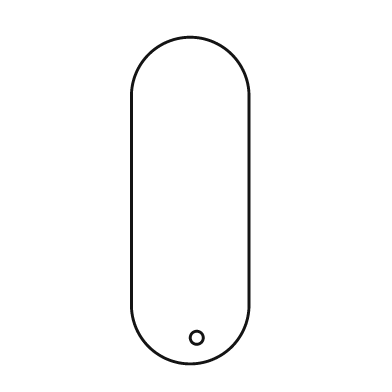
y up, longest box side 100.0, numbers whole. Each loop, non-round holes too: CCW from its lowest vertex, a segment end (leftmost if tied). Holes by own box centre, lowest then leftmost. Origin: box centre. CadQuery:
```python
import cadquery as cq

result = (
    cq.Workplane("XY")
    .moveTo(-18.0, -32.0)
    .threePointArc((0.0, -50.0), (18.0, -32.0))
    .lineTo(18.0, 32.0)
    .threePointArc((0.0, 50.0), (-18.0, 32.0))
    .close()
    .moveTo(2.0, -42.0)
    .circle(2.0)
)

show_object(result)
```